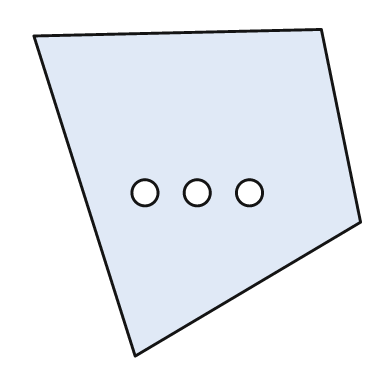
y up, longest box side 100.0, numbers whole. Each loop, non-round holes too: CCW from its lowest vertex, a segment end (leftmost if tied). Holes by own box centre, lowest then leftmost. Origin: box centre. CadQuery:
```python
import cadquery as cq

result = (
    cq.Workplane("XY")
    .moveTo(-19.0, -50.0)
    .lineTo(50.0, -9.0)
    .lineTo(38.0, 50.0)
    .lineTo(-50.0, 48.0)
    .close()
    .moveTo(-16.0, 0.0)
    .circle(4.0)
    .moveTo(0.0, 0.0)
    .circle(4.0)
    .moveTo(16.0, 0.0)
    .circle(4.0)
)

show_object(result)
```